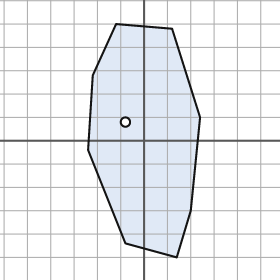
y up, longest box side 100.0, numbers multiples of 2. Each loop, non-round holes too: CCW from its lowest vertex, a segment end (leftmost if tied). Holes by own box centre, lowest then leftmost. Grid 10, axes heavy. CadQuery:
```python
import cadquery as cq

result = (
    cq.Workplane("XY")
    .moveTo(14.0, -50.0)
    .lineTo(20.0, -30.0)
    .lineTo(24.0, 10.0)
    .lineTo(12.0, 48.0)
    .lineTo(-12.0, 50.0)
    .lineTo(-22.0, 28.0)
    .lineTo(-24.0, -4.0)
    .lineTo(-8.0, -44.0)
    .close()
    .moveTo(-8.0, 8.0)
    .circle(2.0)
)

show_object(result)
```